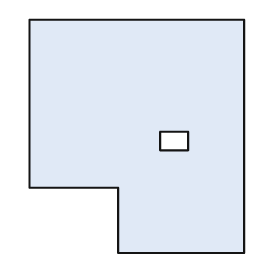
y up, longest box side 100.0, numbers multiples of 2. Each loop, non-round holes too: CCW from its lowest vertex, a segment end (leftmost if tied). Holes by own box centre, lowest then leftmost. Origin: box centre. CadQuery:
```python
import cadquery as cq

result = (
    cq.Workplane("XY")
    .moveTo(-8.0, -50.0)
    .lineTo(46.0, -50.0)
    .lineTo(46.0, 50.0)
    .lineTo(-46.0, 50.0)
    .lineTo(-46.0, -22.0)
    .lineTo(-8.0, -22.0)
    .close()
    .moveTo(10.0, -6.0)
    .lineTo(22.0, -6.0)
    .lineTo(22.0, 2.0)
    .lineTo(10.0, 2.0)
    .close()
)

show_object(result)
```